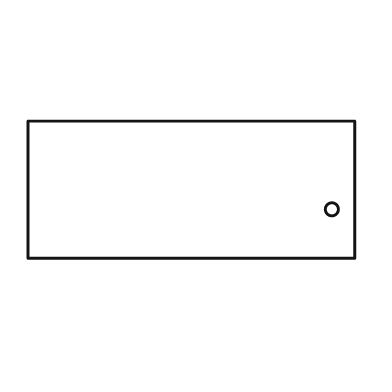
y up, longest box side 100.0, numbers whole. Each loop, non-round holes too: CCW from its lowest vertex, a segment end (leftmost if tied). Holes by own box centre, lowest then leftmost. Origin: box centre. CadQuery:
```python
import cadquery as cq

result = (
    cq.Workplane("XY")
    .moveTo(-50.0, -21.0)
    .lineTo(50.0, -21.0)
    .lineTo(50.0, 21.0)
    .lineTo(-50.0, 21.0)
    .close()
    .moveTo(43.0, -6.0)
    .circle(2.0)
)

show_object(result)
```